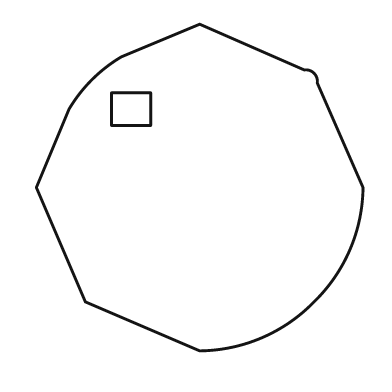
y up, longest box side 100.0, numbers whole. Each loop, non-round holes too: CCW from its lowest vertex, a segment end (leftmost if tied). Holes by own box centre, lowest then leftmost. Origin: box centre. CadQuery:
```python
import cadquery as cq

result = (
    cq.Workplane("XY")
    .moveTo(0.0, -50.0)
    .threePointArc((19.0, -46.0), (35.0, -35.0))
    .threePointArc((46.0, -19.0), (50.0, 0.0))
    .lineTo(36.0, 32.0)
    .threePointArc((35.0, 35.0), (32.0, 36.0))
    .lineTo(0.0, 50.0)
    .lineTo(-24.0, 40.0)
    .threePointArc((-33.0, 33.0), (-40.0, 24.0))
    .lineTo(-50.0, 0.0)
    .lineTo(-35.0, -35.0)
    .close()
    .moveTo(-27.0, 19.0)
    .lineTo(-15.0, 19.0)
    .lineTo(-15.0, 29.0)
    .lineTo(-27.0, 29.0)
    .close()
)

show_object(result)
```